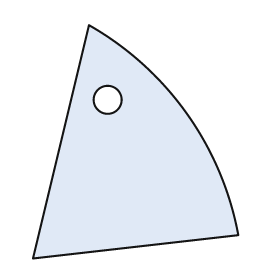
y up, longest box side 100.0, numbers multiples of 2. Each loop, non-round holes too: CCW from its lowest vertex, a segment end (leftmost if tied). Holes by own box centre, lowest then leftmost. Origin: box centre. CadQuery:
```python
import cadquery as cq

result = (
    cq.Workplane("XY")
    .moveTo(-44.0, -50.0)
    .lineTo(44.0, -40.0)
    .threePointArc((22.0, 12.0), (-20.0, 50.0))
    .close()
    .moveTo(-12.0, 18.0)
    .circle(6.0)
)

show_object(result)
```